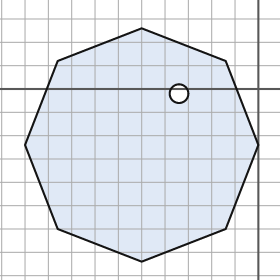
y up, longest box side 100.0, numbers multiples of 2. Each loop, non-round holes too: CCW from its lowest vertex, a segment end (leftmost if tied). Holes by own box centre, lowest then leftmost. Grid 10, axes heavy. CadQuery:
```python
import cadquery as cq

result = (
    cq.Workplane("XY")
    .moveTo(-50.0, -74.0)
    .lineTo(-14.0, -60.0)
    .lineTo(0.0, -24.0)
    .lineTo(-14.0, 12.0)
    .lineTo(-50.0, 26.0)
    .lineTo(-86.0, 12.0)
    .lineTo(-100.0, -24.0)
    .lineTo(-86.0, -60.0)
    .close()
    .moveTo(-34.0, -2.0)
    .circle(4.0)
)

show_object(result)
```